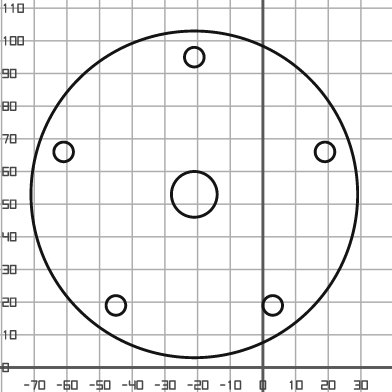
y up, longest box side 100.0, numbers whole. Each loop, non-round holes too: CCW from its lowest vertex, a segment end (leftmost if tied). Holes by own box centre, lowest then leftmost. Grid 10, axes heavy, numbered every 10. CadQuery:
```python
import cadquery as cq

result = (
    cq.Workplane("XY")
    .moveTo(-21.0, 53.0)
    .circle(50.0)
    .moveTo(-45.0, 19.0)
    .circle(3.0)
    .moveTo(3.0, 19.0)
    .circle(3.0)
    .moveTo(-21.0, 53.0)
    .circle(7.0)
    .moveTo(-61.0, 66.0)
    .circle(3.0)
    .moveTo(19.0, 66.0)
    .circle(3.0)
    .moveTo(-21.0, 95.0)
    .circle(3.0)
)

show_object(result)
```